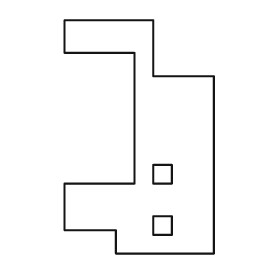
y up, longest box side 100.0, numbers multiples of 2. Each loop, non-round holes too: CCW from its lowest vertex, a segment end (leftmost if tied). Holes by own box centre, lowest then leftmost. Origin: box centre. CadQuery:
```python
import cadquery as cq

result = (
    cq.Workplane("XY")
    .moveTo(-10.0, -50.0)
    .lineTo(32.0, -50.0)
    .lineTo(32.0, 26.0)
    .lineTo(6.0, 26.0)
    .lineTo(6.0, 50.0)
    .lineTo(-32.0, 50.0)
    .lineTo(-32.0, 36.0)
    .lineTo(-2.0, 36.0)
    .lineTo(-2.0, -20.0)
    .lineTo(-32.0, -20.0)
    .lineTo(-32.0, -40.0)
    .lineTo(-10.0, -40.0)
    .close()
    .moveTo(6.0, -42.0)
    .lineTo(14.0, -42.0)
    .lineTo(14.0, -34.0)
    .lineTo(6.0, -34.0)
    .close()
    .moveTo(6.0, -20.0)
    .lineTo(14.0, -20.0)
    .lineTo(14.0, -12.0)
    .lineTo(6.0, -12.0)
    .close()
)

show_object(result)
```